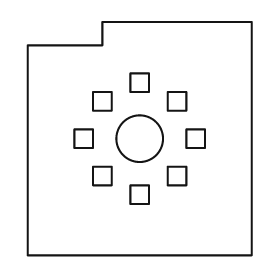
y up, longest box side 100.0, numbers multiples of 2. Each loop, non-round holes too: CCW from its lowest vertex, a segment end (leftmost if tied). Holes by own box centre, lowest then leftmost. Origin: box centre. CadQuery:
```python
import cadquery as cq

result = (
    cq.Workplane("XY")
    .moveTo(-48.0, -50.0)
    .lineTo(48.0, -50.0)
    .lineTo(48.0, 50.0)
    .lineTo(-16.0, 50.0)
    .lineTo(-16.0, 40.0)
    .lineTo(-48.0, 40.0)
    .close()
    .moveTo(-4.0, -28.0)
    .lineTo(4.0, -28.0)
    .lineTo(4.0, -20.0)
    .lineTo(-4.0, -20.0)
    .close()
    .moveTo(-20.0, -20.0)
    .lineTo(-12.0, -20.0)
    .lineTo(-12.0, -12.0)
    .lineTo(-20.0, -12.0)
    .close()
    .moveTo(12.0, -20.0)
    .lineTo(20.0, -20.0)
    .lineTo(20.0, -12.0)
    .lineTo(12.0, -12.0)
    .close()
    .moveTo(-28.0, -4.0)
    .lineTo(-20.0, -4.0)
    .lineTo(-20.0, 4.0)
    .lineTo(-28.0, 4.0)
    .close()
    .moveTo(0.0, 0.0)
    .circle(10.0)
    .moveTo(20.0, -4.0)
    .lineTo(28.0, -4.0)
    .lineTo(28.0, 4.0)
    .lineTo(20.0, 4.0)
    .close()
    .moveTo(-20.0, 12.0)
    .lineTo(-12.0, 12.0)
    .lineTo(-12.0, 20.0)
    .lineTo(-20.0, 20.0)
    .close()
    .moveTo(12.0, 12.0)
    .lineTo(20.0, 12.0)
    .lineTo(20.0, 20.0)
    .lineTo(12.0, 20.0)
    .close()
    .moveTo(-4.0, 20.0)
    .lineTo(4.0, 20.0)
    .lineTo(4.0, 28.0)
    .lineTo(-4.0, 28.0)
    .close()
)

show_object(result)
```